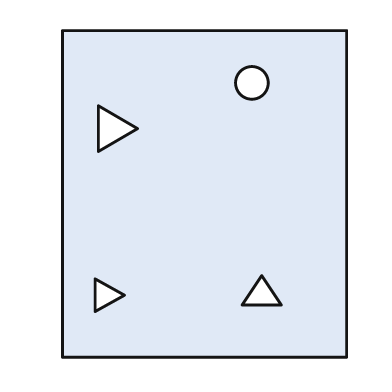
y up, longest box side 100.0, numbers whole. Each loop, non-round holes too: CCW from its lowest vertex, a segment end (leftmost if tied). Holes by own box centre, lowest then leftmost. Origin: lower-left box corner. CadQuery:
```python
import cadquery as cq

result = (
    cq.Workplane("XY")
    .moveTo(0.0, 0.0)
    .lineTo(87.0, 0.0)
    .lineTo(87.0, 100.0)
    .lineTo(0.0, 100.0)
    .close()
    .moveTo(10.0, 14.0)
    .lineTo(19.0, 19.0)
    .lineTo(10.0, 24.0)
    .close()
    .moveTo(55.0, 16.0)
    .lineTo(67.0, 16.0)
    .lineTo(61.0, 25.0)
    .close()
    .moveTo(11.0, 63.0)
    .lineTo(23.0, 70.0)
    .lineTo(11.0, 77.0)
    .close()
    .moveTo(58.0, 84.0)
    .circle(5.0)
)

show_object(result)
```